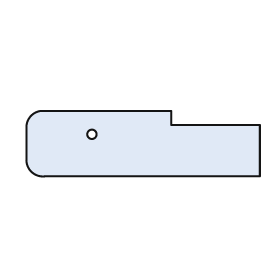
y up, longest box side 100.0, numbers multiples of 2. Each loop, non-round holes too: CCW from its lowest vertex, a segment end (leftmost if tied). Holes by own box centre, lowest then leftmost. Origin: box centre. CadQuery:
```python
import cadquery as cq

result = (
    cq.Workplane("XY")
    .moveTo(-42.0, -14.0)
    .lineTo(50.0, -14.0)
    .lineTo(50.0, 8.0)
    .lineTo(12.0, 8.0)
    .lineTo(12.0, 14.0)
    .lineTo(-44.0, 14.0)
    .threePointArc((-48.0, 12.0), (-50.0, 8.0))
    .lineTo(-50.0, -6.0)
    .threePointArc((-48.0, -12.0), (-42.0, -14.0))
    .close()
    .moveTo(-22.0, 4.0)
    .circle(2.0)
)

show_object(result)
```